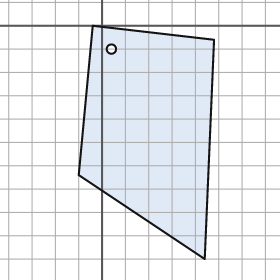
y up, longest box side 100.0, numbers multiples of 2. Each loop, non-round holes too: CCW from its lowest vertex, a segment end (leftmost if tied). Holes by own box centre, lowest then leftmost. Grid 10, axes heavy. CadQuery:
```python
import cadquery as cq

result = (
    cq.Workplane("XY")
    .moveTo(44.0, -100.0)
    .lineTo(48.0, -6.0)
    .lineTo(-4.0, 0.0)
    .lineTo(-10.0, -64.0)
    .close()
    .moveTo(4.0, -10.0)
    .circle(2.0)
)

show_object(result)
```